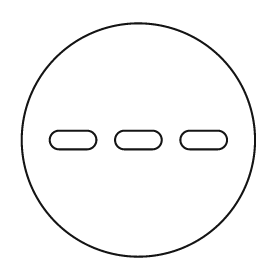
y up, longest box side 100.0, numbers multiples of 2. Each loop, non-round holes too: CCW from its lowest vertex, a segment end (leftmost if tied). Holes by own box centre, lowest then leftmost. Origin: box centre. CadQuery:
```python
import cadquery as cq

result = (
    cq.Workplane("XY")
    .moveTo(0.0, 0.0)
    .circle(50.0)
    .moveTo(-34.0, -4.0)
    .lineTo(-22.0, -4.0)
    .threePointArc((-18.0, 0.0), (-22.0, 4.0))
    .lineTo(-34.0, 4.0)
    .threePointArc((-38.0, 0.0), (-34.0, -4.0))
    .close()
    .moveTo(-6.0, -4.0)
    .lineTo(6.0, -4.0)
    .threePointArc((10.0, 0.0), (6.0, 4.0))
    .lineTo(-6.0, 4.0)
    .threePointArc((-10.0, 0.0), (-6.0, -4.0))
    .close()
    .moveTo(22.0, -4.0)
    .lineTo(34.0, -4.0)
    .threePointArc((38.0, 0.0), (34.0, 4.0))
    .lineTo(22.0, 4.0)
    .threePointArc((18.0, 0.0), (22.0, -4.0))
    .close()
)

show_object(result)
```